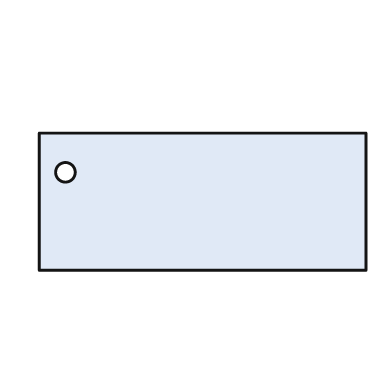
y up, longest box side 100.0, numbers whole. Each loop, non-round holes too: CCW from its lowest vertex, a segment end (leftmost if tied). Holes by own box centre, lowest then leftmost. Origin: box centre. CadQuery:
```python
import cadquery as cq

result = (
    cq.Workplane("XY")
    .moveTo(-50.0, -21.0)
    .lineTo(50.0, -21.0)
    .lineTo(50.0, 21.0)
    .lineTo(-50.0, 21.0)
    .close()
    .moveTo(-42.0, 9.0)
    .circle(3.0)
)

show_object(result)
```